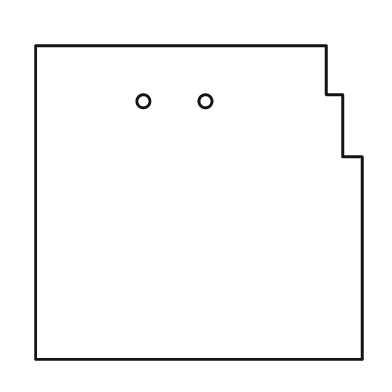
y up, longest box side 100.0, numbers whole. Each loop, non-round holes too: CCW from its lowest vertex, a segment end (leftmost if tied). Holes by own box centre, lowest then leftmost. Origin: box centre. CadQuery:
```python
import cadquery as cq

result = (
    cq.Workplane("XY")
    .moveTo(-50.0, -48.0)
    .lineTo(50.0, -48.0)
    .lineTo(50.0, 14.0)
    .lineTo(44.0, 14.0)
    .lineTo(44.0, 33.0)
    .lineTo(39.0, 33.0)
    .lineTo(39.0, 48.0)
    .lineTo(-50.0, 48.0)
    .close()
    .moveTo(-17.0, 31.0)
    .circle(2.0)
    .moveTo(2.0, 31.0)
    .circle(2.0)
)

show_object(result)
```